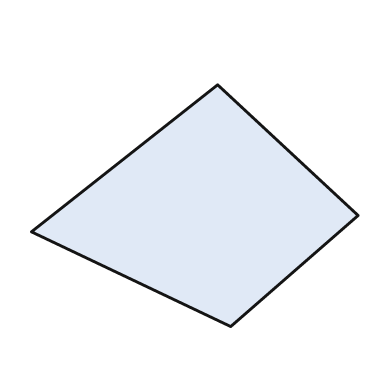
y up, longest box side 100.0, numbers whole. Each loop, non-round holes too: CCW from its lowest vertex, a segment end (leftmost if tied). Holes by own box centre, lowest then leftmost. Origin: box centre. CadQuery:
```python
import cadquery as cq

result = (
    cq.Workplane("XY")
    .moveTo(11.0, -37.0)
    .lineTo(50.0, -3.0)
    .lineTo(7.0, 37.0)
    .lineTo(-50.0, -8.0)
    .close()
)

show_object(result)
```